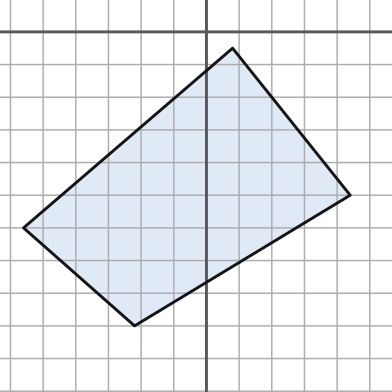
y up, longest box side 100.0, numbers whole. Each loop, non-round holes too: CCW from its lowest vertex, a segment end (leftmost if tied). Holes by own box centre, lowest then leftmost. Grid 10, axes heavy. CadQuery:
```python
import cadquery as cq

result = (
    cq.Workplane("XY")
    .moveTo(-22.0, -90.0)
    .lineTo(44.0, -50.0)
    .lineTo(8.0, -5.0)
    .lineTo(-56.0, -60.0)
    .close()
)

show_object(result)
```